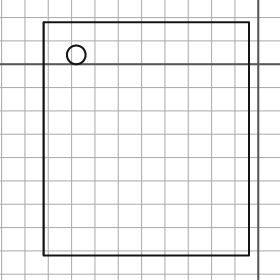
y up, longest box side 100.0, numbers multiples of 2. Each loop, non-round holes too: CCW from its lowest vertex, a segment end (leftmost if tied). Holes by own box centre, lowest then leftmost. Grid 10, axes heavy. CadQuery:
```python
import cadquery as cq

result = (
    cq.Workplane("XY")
    .moveTo(-92.0, -82.0)
    .lineTo(-4.0, -82.0)
    .lineTo(-4.0, 18.0)
    .lineTo(-92.0, 18.0)
    .close()
    .moveTo(-78.0, 4.0)
    .circle(4.0)
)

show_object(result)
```